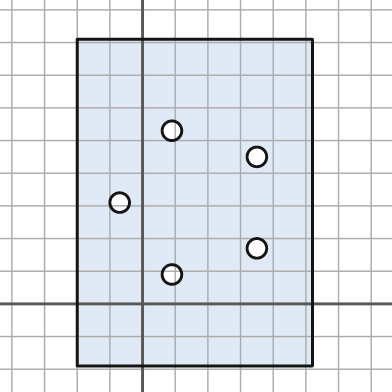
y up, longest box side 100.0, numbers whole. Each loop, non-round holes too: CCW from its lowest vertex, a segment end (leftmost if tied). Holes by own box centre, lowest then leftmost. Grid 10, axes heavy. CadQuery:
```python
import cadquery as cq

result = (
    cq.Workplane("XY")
    .moveTo(-20.0, -19.0)
    .lineTo(52.0, -19.0)
    .lineTo(52.0, 81.0)
    .lineTo(-20.0, 81.0)
    .close()
    .moveTo(9.0, 9.0)
    .circle(3.0)
    .moveTo(35.0, 17.0)
    .circle(3.0)
    .moveTo(-7.0, 31.0)
    .circle(3.0)
    .moveTo(35.0, 45.0)
    .circle(3.0)
    .moveTo(9.0, 53.0)
    .circle(3.0)
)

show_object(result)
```